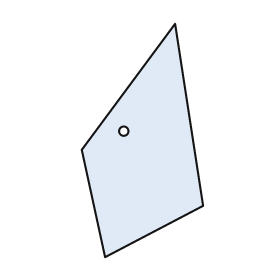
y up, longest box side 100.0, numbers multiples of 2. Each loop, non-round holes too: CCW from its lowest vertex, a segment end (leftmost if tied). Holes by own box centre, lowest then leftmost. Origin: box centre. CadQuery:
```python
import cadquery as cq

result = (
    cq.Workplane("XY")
    .moveTo(-16.0, -50.0)
    .lineTo(26.0, -28.0)
    .lineTo(14.0, 50.0)
    .lineTo(-26.0, -4.0)
    .close()
    .moveTo(-8.0, 4.0)
    .circle(2.0)
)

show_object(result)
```